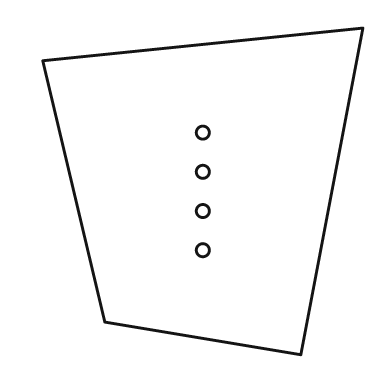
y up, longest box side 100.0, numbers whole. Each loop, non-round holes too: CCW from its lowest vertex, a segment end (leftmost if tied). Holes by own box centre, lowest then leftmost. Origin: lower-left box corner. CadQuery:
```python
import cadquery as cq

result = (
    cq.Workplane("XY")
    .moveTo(79.0, 0.0)
    .lineTo(98.0, 100.0)
    .lineTo(0.0, 90.0)
    .lineTo(19.0, 10.0)
    .close()
    .moveTo(49.0, 32.0)
    .circle(2.0)
    .moveTo(49.0, 44.0)
    .circle(2.0)
    .moveTo(49.0, 56.0)
    .circle(2.0)
    .moveTo(49.0, 68.0)
    .circle(2.0)
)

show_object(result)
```